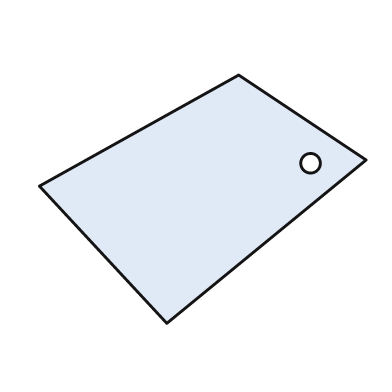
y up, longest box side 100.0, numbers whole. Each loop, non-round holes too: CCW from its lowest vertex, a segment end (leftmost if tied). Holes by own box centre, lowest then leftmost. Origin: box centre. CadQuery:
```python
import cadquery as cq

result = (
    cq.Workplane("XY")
    .moveTo(-11.0, -38.0)
    .lineTo(50.0, 12.0)
    .lineTo(11.0, 38.0)
    .lineTo(-50.0, 4.0)
    .close()
    .moveTo(33.0, 11.0)
    .circle(3.0)
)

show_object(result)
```